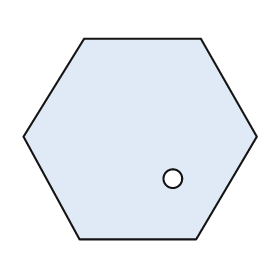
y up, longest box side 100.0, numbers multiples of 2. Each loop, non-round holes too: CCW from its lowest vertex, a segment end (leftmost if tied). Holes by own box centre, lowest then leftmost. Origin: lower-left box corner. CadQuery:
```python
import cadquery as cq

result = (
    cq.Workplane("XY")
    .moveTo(24.0, 0.0)
    .lineTo(74.0, 0.0)
    .lineTo(100.0, 44.0)
    .lineTo(76.0, 86.0)
    .lineTo(26.0, 86.0)
    .lineTo(0.0, 44.0)
    .close()
    .moveTo(64.0, 26.0)
    .circle(4.0)
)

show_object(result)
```